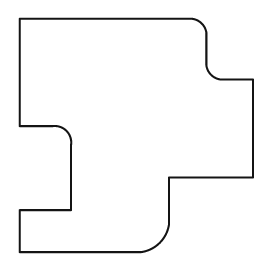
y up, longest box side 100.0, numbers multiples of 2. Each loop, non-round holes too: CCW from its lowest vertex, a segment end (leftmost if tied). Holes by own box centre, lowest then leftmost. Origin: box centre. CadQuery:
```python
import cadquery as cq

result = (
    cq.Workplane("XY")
    .moveTo(-50.0, -50.0)
    .lineTo(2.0, -50.0)
    .threePointArc((10.0, -46.0), (14.0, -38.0))
    .lineTo(14.0, -18.0)
    .lineTo(50.0, -18.0)
    .lineTo(50.0, 24.0)
    .lineTo(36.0, 24.0)
    .threePointArc((32.0, 26.0), (30.0, 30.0))
    .lineTo(30.0, 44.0)
    .threePointArc((28.0, 48.0), (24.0, 50.0))
    .lineTo(-50.0, 50.0)
    .lineTo(-50.0, 4.0)
    .lineTo(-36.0, 4.0)
    .threePointArc((-30.0, 2.0), (-28.0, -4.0))
    .lineTo(-28.0, -32.0)
    .lineTo(-50.0, -32.0)
    .close()
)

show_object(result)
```